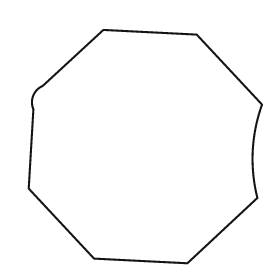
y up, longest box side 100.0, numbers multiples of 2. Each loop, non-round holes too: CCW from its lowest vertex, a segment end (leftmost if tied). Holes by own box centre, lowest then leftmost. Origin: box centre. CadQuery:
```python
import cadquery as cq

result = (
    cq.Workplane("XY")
    .moveTo(18.0, -50.0)
    .lineTo(48.0, -22.0)
    .threePointArc((46.0, -2.0), (50.0, 18.0))
    .lineTo(22.0, 48.0)
    .lineTo(-18.0, 50.0)
    .lineTo(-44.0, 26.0)
    .threePointArc((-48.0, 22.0), (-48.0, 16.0))
    .lineTo(-50.0, -18.0)
    .lineTo(-22.0, -48.0)
    .close()
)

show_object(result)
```